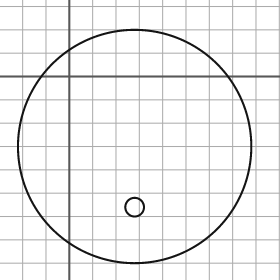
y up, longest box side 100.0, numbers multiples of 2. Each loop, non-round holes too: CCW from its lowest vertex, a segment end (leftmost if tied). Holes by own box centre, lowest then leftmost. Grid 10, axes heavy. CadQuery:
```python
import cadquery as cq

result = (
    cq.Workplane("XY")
    .moveTo(28.0, -30.0)
    .circle(50.0)
    .moveTo(28.0, -56.0)
    .circle(4.0)
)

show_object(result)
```